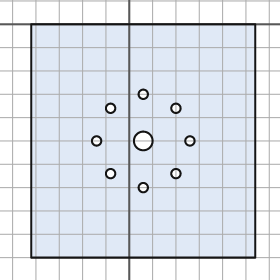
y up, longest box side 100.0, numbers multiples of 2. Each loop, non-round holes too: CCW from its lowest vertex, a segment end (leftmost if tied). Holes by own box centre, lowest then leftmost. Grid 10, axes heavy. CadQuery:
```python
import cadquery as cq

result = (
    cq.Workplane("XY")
    .moveTo(-42.0, -100.0)
    .lineTo(54.0, -100.0)
    .lineTo(54.0, 0.0)
    .lineTo(-42.0, 0.0)
    .close()
    .moveTo(6.0, -70.0)
    .circle(2.0)
    .moveTo(-8.0, -64.0)
    .circle(2.0)
    .moveTo(20.0, -64.0)
    .circle(2.0)
    .moveTo(-14.0, -50.0)
    .circle(2.0)
    .moveTo(6.0, -50.0)
    .circle(4.0)
    .moveTo(26.0, -50.0)
    .circle(2.0)
    .moveTo(-8.0, -36.0)
    .circle(2.0)
    .moveTo(20.0, -36.0)
    .circle(2.0)
    .moveTo(6.0, -30.0)
    .circle(2.0)
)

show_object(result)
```